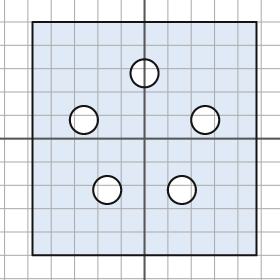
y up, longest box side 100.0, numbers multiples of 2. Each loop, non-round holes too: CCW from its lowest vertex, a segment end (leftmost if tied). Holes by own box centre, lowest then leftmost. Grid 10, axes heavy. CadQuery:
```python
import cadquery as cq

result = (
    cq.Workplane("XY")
    .moveTo(-48.0, -50.0)
    .lineTo(48.0, -50.0)
    .lineTo(48.0, 50.0)
    .lineTo(-48.0, 50.0)
    .close()
    .moveTo(-16.0, -22.0)
    .circle(6.0)
    .moveTo(16.0, -22.0)
    .circle(6.0)
    .moveTo(-26.0, 8.0)
    .circle(6.0)
    .moveTo(26.0, 8.0)
    .circle(6.0)
    .moveTo(0.0, 28.0)
    .circle(6.0)
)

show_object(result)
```